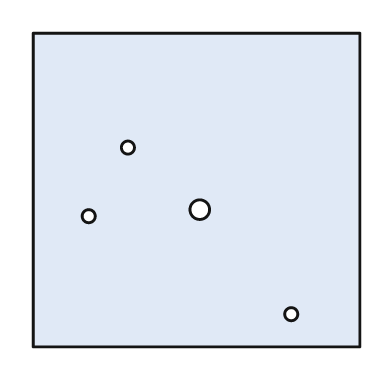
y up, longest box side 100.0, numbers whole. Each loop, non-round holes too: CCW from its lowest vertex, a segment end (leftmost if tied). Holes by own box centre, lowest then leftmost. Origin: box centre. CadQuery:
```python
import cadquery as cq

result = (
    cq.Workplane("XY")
    .moveTo(-50.0, -48.0)
    .lineTo(50.0, -48.0)
    .lineTo(50.0, 48.0)
    .lineTo(-50.0, 48.0)
    .close()
    .moveTo(29.0, -38.0)
    .circle(2.0)
    .moveTo(-33.0, -8.0)
    .circle(2.0)
    .moveTo(1.0, -6.0)
    .circle(3.0)
    .moveTo(-21.0, 13.0)
    .circle(2.0)
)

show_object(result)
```